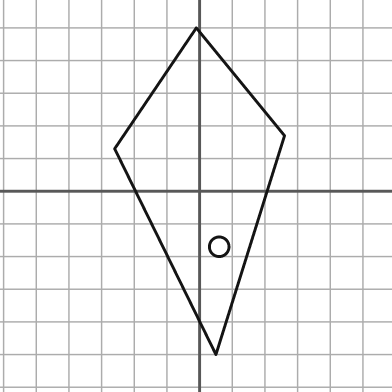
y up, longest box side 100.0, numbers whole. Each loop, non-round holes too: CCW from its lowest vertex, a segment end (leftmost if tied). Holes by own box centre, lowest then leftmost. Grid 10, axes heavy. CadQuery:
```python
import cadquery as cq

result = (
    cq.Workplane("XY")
    .moveTo(5.0, -50.0)
    .lineTo(26.0, 17.0)
    .lineTo(-1.0, 50.0)
    .lineTo(-26.0, 13.0)
    .close()
    .moveTo(6.0, -17.0)
    .circle(3.0)
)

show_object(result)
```